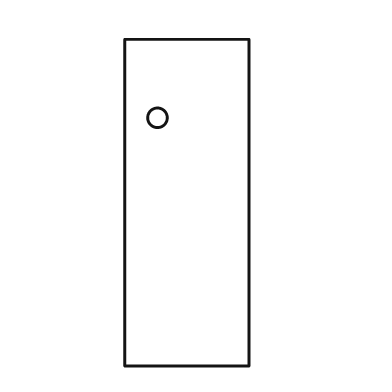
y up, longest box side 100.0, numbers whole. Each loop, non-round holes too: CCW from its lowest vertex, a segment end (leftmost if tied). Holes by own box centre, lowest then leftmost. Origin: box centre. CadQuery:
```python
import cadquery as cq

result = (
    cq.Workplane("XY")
    .moveTo(-19.0, -50.0)
    .lineTo(19.0, -50.0)
    .lineTo(19.0, 50.0)
    .lineTo(-19.0, 50.0)
    .close()
    .moveTo(-9.0, 26.0)
    .circle(3.0)
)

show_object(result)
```